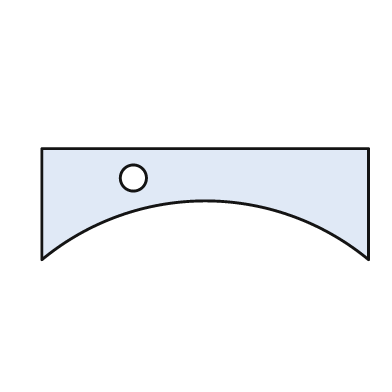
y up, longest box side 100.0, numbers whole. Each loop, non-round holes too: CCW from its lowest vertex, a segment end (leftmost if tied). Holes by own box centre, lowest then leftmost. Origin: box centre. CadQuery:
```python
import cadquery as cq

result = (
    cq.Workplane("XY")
    .moveTo(-50.0, -17.0)
    .threePointArc((0.0, 1.0), (50.0, -17.0))
    .lineTo(50.0, 17.0)
    .lineTo(-50.0, 17.0)
    .close()
    .moveTo(-22.0, 8.0)
    .circle(4.0)
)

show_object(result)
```